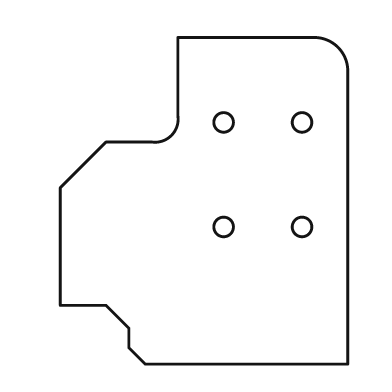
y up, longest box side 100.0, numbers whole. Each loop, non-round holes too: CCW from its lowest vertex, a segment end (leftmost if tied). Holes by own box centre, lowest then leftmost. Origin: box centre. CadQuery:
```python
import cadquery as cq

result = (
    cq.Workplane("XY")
    .moveTo(-18.0, -50.0)
    .lineTo(44.0, -50.0)
    .lineTo(44.0, 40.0)
    .threePointArc((41.0, 47.0), (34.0, 50.0))
    .lineTo(-8.0, 50.0)
    .lineTo(-8.0, 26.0)
    .threePointArc((-10.0, 20.0), (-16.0, 18.0))
    .lineTo(-30.0, 18.0)
    .lineTo(-44.0, 4.0)
    .lineTo(-44.0, -32.0)
    .lineTo(-30.0, -32.0)
    .lineTo(-23.0, -39.0)
    .lineTo(-23.0, -45.0)
    .close()
    .moveTo(6.0, -8.0)
    .circle(3.0)
    .moveTo(30.0, -8.0)
    .circle(3.0)
    .moveTo(6.0, 24.0)
    .circle(3.0)
    .moveTo(30.0, 24.0)
    .circle(3.0)
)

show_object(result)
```